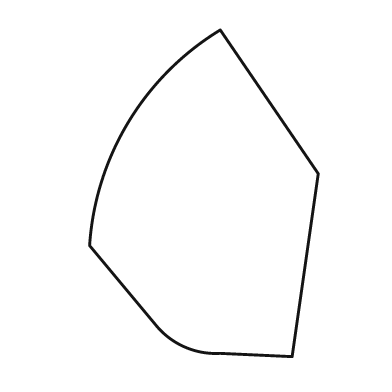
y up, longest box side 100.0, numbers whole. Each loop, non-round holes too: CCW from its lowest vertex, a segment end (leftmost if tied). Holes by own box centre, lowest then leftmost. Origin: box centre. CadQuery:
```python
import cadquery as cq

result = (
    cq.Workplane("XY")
    .moveTo(27.0, -50.0)
    .lineTo(35.0, 6.0)
    .lineTo(5.0, 50.0)
    .threePointArc((-23.0, 22.0), (-35.0, -16.0))
    .lineTo(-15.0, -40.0)
    .threePointArc((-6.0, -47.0), (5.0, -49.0))
    .close()
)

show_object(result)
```